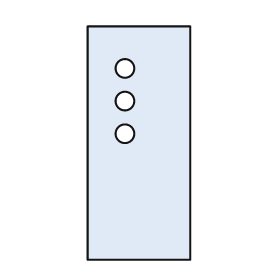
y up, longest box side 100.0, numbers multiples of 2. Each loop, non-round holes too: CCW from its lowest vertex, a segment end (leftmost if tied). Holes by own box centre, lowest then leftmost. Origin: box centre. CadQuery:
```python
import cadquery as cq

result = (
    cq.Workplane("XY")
    .moveTo(-22.0, -50.0)
    .lineTo(22.0, -50.0)
    .lineTo(22.0, 50.0)
    .lineTo(-22.0, 50.0)
    .close()
    .moveTo(-6.0, 4.0)
    .circle(4.0)
    .moveTo(-6.0, 18.0)
    .circle(4.0)
    .moveTo(-6.0, 32.0)
    .circle(4.0)
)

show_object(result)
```